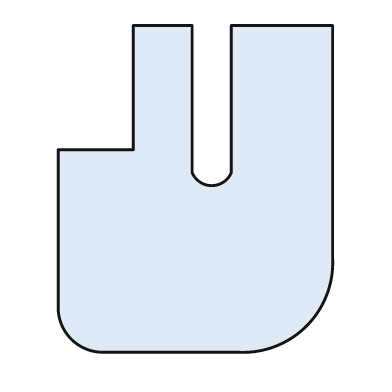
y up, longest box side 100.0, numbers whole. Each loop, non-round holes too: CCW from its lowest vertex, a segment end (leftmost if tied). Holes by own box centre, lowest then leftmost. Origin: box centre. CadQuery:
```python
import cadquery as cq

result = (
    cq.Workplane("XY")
    .moveTo(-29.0, -50.0)
    .lineTo(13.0, -50.0)
    .threePointArc((34.0, -42.0), (42.0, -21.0))
    .lineTo(42.0, 50.0)
    .lineTo(11.0, 50.0)
    .lineTo(11.0, 5.0)
    .threePointArc((5.0, 1.0), (-1.0, 5.0))
    .lineTo(-1.0, 50.0)
    .lineTo(-19.0, 50.0)
    .lineTo(-19.0, 12.0)
    .lineTo(-42.0, 12.0)
    .lineTo(-42.0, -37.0)
    .threePointArc((-38.0, -46.0), (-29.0, -50.0))
    .close()
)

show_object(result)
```